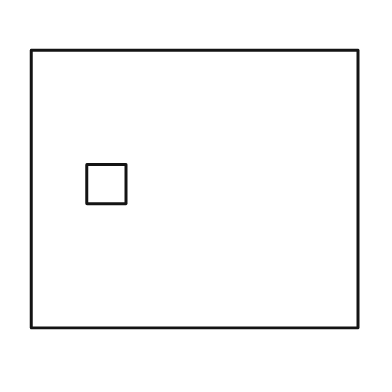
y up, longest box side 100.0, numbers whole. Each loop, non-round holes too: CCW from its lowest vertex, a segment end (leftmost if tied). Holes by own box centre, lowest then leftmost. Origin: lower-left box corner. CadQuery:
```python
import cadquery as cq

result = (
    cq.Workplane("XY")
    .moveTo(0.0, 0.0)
    .lineTo(100.0, 0.0)
    .lineTo(100.0, 85.0)
    .lineTo(0.0, 85.0)
    .close()
    .moveTo(17.0, 38.0)
    .lineTo(29.0, 38.0)
    .lineTo(29.0, 50.0)
    .lineTo(17.0, 50.0)
    .close()
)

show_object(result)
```